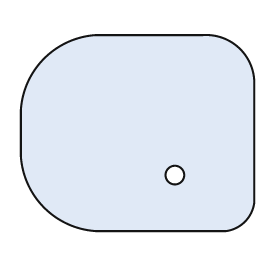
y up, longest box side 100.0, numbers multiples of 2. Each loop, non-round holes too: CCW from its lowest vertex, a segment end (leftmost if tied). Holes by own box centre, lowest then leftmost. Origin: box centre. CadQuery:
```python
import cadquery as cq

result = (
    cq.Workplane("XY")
    .moveTo(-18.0, -42.0)
    .lineTo(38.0, -42.0)
    .threePointArc((46.0, -38.0), (50.0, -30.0))
    .lineTo(50.0, 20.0)
    .threePointArc((44.0, 36.0), (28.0, 42.0))
    .lineTo(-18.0, 42.0)
    .threePointArc((-40.0, 32.0), (-50.0, 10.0))
    .lineTo(-50.0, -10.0)
    .threePointArc((-40.0, -32.0), (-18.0, -42.0))
    .close()
    .moveTo(16.0, -18.0)
    .circle(4.0)
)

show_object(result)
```